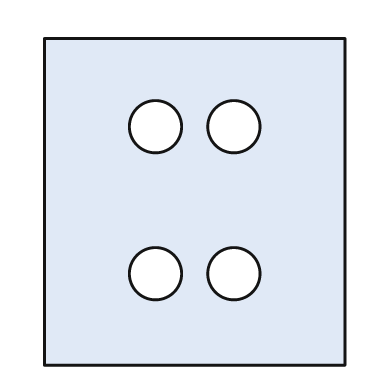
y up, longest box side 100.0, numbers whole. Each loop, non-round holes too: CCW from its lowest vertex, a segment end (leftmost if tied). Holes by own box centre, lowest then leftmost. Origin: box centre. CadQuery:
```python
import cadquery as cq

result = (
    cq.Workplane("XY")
    .moveTo(-46.0, -50.0)
    .lineTo(46.0, -50.0)
    .lineTo(46.0, 50.0)
    .lineTo(-46.0, 50.0)
    .close()
    .moveTo(-12.0, -22.0)
    .circle(8.0)
    .moveTo(12.0, -22.0)
    .circle(8.0)
    .moveTo(-12.0, 23.0)
    .circle(8.0)
    .moveTo(12.0, 23.0)
    .circle(8.0)
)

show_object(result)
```